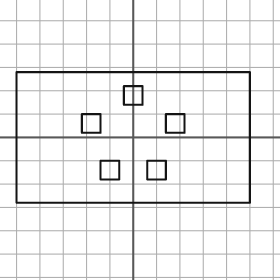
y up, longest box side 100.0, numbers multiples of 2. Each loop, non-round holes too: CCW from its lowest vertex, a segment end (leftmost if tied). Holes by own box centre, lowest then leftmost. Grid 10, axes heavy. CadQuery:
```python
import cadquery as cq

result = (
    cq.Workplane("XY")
    .moveTo(-50.0, -28.0)
    .lineTo(50.0, -28.0)
    .lineTo(50.0, 28.0)
    .lineTo(-50.0, 28.0)
    .close()
    .moveTo(-14.0, -18.0)
    .lineTo(-6.0, -18.0)
    .lineTo(-6.0, -10.0)
    .lineTo(-14.0, -10.0)
    .close()
    .moveTo(6.0, -18.0)
    .lineTo(14.0, -18.0)
    .lineTo(14.0, -10.0)
    .lineTo(6.0, -10.0)
    .close()
    .moveTo(-22.0, 2.0)
    .lineTo(-14.0, 2.0)
    .lineTo(-14.0, 10.0)
    .lineTo(-22.0, 10.0)
    .close()
    .moveTo(14.0, 2.0)
    .lineTo(22.0, 2.0)
    .lineTo(22.0, 10.0)
    .lineTo(14.0, 10.0)
    .close()
    .moveTo(-4.0, 14.0)
    .lineTo(4.0, 14.0)
    .lineTo(4.0, 22.0)
    .lineTo(-4.0, 22.0)
    .close()
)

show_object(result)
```